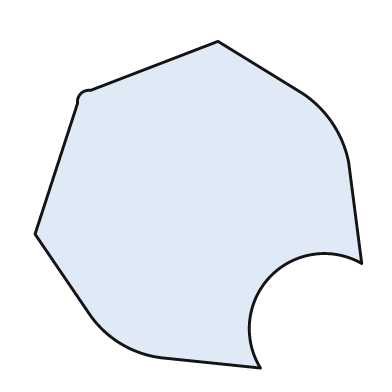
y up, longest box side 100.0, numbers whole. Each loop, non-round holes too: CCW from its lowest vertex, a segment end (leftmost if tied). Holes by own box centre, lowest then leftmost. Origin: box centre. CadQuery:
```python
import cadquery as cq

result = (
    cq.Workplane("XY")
    .moveTo(19.0, -50.0)
    .threePointArc((22.0, -22.0), (50.0, -18.0))
    .lineTo(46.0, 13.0)
    .threePointArc((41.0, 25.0), (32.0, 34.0))
    .lineTo(6.0, 50.0)
    .lineTo(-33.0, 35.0)
    .threePointArc((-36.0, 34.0), (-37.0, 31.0))
    .lineTo(-50.0, -9.0)
    .lineTo(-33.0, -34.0)
    .threePointArc((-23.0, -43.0), (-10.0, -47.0))
    .close()
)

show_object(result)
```